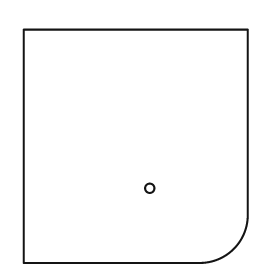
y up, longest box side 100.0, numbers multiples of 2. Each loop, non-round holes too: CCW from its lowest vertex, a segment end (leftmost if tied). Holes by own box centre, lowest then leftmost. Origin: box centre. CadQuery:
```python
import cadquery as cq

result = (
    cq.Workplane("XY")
    .moveTo(-48.0, -50.0)
    .lineTo(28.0, -50.0)
    .threePointArc((42.0, -44.0), (48.0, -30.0))
    .lineTo(48.0, 50.0)
    .lineTo(-48.0, 50.0)
    .close()
    .moveTo(6.0, -18.0)
    .circle(2.0)
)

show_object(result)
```